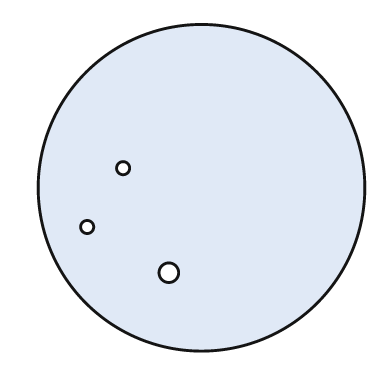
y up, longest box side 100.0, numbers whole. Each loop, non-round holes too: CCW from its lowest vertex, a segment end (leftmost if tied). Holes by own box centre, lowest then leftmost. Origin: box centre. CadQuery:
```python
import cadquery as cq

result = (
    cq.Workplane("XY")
    .moveTo(0.0, 0.0)
    .circle(50.0)
    .moveTo(-10.0, -26.0)
    .circle(3.0)
    .moveTo(-35.0, -12.0)
    .circle(2.0)
    .moveTo(-24.0, 6.0)
    .circle(2.0)
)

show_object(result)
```